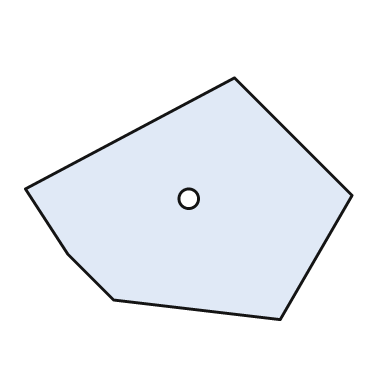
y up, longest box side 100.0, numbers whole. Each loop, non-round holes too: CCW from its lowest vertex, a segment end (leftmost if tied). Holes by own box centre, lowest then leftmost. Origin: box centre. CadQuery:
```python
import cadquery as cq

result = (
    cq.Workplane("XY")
    .moveTo(28.0, -37.0)
    .lineTo(50.0, 1.0)
    .lineTo(14.0, 37.0)
    .lineTo(-50.0, 3.0)
    .lineTo(-37.0, -17.0)
    .lineTo(-23.0, -31.0)
    .close()
    .moveTo(0.0, 0.0)
    .circle(3.0)
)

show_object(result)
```